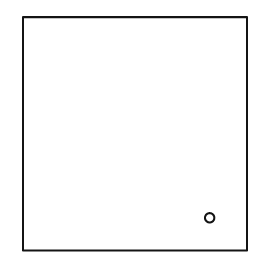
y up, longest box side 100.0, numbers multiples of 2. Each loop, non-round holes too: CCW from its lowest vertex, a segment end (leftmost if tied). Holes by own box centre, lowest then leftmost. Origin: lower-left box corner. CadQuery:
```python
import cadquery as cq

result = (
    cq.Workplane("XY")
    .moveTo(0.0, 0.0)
    .lineTo(96.0, 0.0)
    .lineTo(96.0, 100.0)
    .lineTo(0.0, 100.0)
    .close()
    .moveTo(80.0, 14.0)
    .circle(2.0)
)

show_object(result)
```